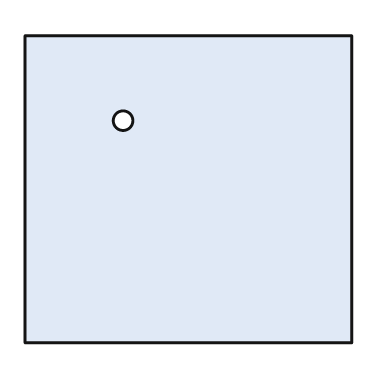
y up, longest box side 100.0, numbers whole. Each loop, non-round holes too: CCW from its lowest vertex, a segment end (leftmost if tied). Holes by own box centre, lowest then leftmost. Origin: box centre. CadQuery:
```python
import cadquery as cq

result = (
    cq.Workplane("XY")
    .moveTo(-50.0, -47.0)
    .lineTo(50.0, -47.0)
    .lineTo(50.0, 47.0)
    .lineTo(-50.0, 47.0)
    .close()
    .moveTo(-20.0, 21.0)
    .circle(3.0)
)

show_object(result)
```